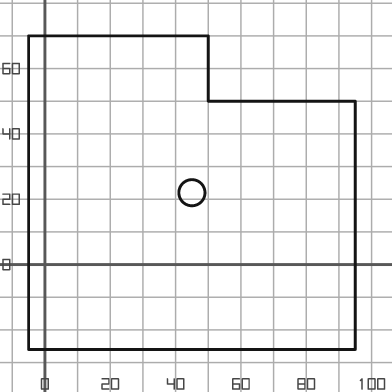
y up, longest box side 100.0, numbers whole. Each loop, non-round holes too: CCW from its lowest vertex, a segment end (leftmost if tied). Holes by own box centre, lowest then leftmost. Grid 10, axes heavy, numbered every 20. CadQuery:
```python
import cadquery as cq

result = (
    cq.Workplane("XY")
    .moveTo(-5.0, -26.0)
    .lineTo(95.0, -26.0)
    .lineTo(95.0, 50.0)
    .lineTo(50.0, 50.0)
    .lineTo(50.0, 70.0)
    .lineTo(-5.0, 70.0)
    .close()
    .moveTo(45.0, 22.0)
    .circle(4.0)
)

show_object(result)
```